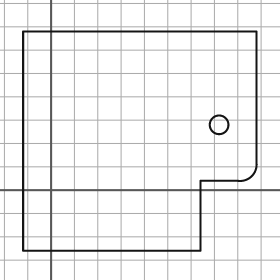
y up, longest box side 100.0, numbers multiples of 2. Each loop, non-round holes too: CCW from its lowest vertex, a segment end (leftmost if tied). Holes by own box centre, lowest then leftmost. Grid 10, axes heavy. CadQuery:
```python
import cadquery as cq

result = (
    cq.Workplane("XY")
    .moveTo(-12.0, -26.0)
    .lineTo(64.0, -26.0)
    .lineTo(64.0, 4.0)
    .lineTo(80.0, 4.0)
    .threePointArc((86.0, 6.0), (88.0, 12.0))
    .lineTo(88.0, 68.0)
    .lineTo(-12.0, 68.0)
    .close()
    .moveTo(72.0, 28.0)
    .circle(4.0)
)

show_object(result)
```